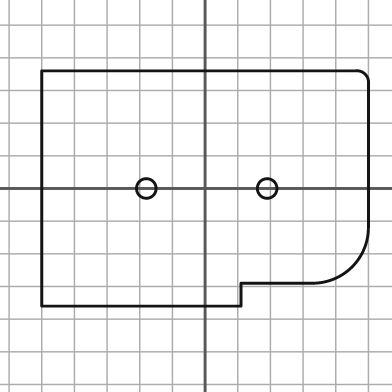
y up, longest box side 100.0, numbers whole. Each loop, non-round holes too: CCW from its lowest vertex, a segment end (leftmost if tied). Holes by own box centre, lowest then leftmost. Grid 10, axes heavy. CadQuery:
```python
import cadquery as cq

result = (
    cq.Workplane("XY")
    .moveTo(-50.0, -36.0)
    .lineTo(11.0, -36.0)
    .lineTo(11.0, -29.0)
    .lineTo(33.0, -29.0)
    .threePointArc((45.0, -24.0), (50.0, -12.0))
    .lineTo(50.0, 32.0)
    .threePointArc((49.0, 35.0), (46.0, 36.0))
    .lineTo(-50.0, 36.0)
    .close()
    .moveTo(-18.0, 0.0)
    .circle(3.0)
    .moveTo(19.0, 0.0)
    .circle(3.0)
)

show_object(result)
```